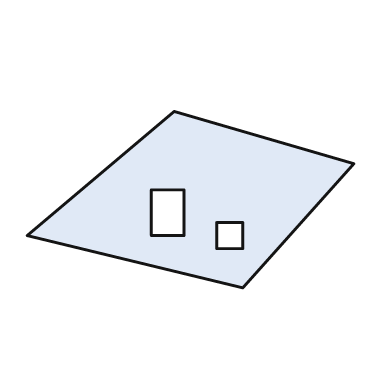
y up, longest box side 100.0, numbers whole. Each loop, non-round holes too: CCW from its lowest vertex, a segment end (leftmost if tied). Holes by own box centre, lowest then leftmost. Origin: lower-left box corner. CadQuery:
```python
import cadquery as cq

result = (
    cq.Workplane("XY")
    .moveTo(66.0, 0.0)
    .lineTo(100.0, 38.0)
    .lineTo(45.0, 54.0)
    .lineTo(0.0, 16.0)
    .close()
    .moveTo(58.0, 12.0)
    .lineTo(66.0, 12.0)
    .lineTo(66.0, 20.0)
    .lineTo(58.0, 20.0)
    .close()
    .moveTo(38.0, 16.0)
    .lineTo(48.0, 16.0)
    .lineTo(48.0, 30.0)
    .lineTo(38.0, 30.0)
    .close()
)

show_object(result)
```